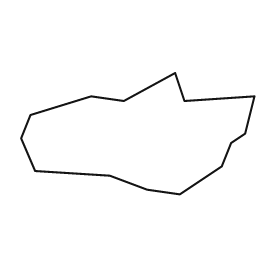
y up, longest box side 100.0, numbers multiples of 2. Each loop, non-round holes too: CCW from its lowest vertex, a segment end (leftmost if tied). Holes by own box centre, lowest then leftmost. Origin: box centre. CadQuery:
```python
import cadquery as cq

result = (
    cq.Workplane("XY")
    .moveTo(18.0, -26.0)
    .lineTo(36.0, -14.0)
    .lineTo(40.0, -4.0)
    .lineTo(46.0, 0.0)
    .lineTo(50.0, 16.0)
    .lineTo(20.0, 14.0)
    .lineTo(16.0, 26.0)
    .lineTo(-6.0, 14.0)
    .lineTo(-20.0, 16.0)
    .lineTo(-46.0, 8.0)
    .lineTo(-50.0, -2.0)
    .lineTo(-44.0, -16.0)
    .lineTo(-12.0, -18.0)
    .lineTo(4.0, -24.0)
    .close()
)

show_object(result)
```